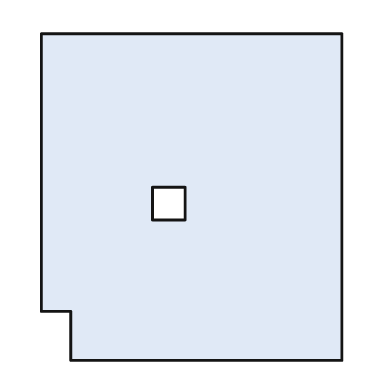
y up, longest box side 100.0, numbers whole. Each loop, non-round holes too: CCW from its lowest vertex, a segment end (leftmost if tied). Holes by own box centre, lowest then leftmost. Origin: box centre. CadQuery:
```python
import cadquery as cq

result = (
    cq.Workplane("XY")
    .moveTo(-37.0, -50.0)
    .lineTo(46.0, -50.0)
    .lineTo(46.0, 50.0)
    .lineTo(-46.0, 50.0)
    .lineTo(-46.0, -35.0)
    .lineTo(-37.0, -35.0)
    .close()
    .moveTo(-12.0, -7.0)
    .lineTo(-2.0, -7.0)
    .lineTo(-2.0, 3.0)
    .lineTo(-12.0, 3.0)
    .close()
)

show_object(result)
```